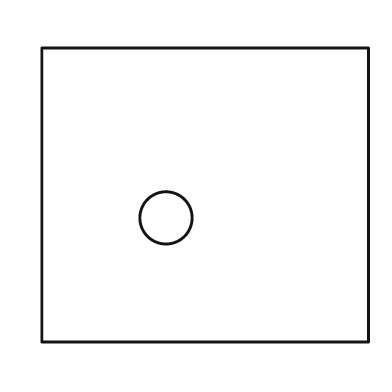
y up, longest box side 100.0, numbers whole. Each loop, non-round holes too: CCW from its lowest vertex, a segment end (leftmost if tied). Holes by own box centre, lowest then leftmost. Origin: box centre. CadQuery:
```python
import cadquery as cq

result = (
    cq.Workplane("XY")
    .moveTo(-50.0, -45.0)
    .lineTo(50.0, -45.0)
    .lineTo(50.0, 45.0)
    .lineTo(-50.0, 45.0)
    .close()
    .moveTo(-12.0, -7.0)
    .circle(8.0)
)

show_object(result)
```